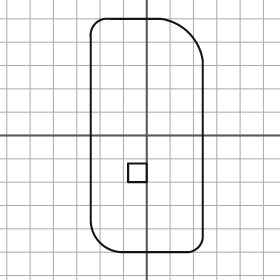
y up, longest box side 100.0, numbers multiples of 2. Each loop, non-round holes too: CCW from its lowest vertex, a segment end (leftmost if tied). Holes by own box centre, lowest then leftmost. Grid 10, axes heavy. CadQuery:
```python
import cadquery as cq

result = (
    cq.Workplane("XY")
    .moveTo(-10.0, -50.0)
    .lineTo(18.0, -50.0)
    .threePointArc((22.0, -48.0), (24.0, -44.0))
    .lineTo(24.0, 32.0)
    .threePointArc((18.0, 44.0), (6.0, 50.0))
    .lineTo(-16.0, 50.0)
    .threePointArc((-22.0, 48.0), (-24.0, 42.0))
    .lineTo(-24.0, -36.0)
    .threePointArc((-20.0, -46.0), (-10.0, -50.0))
    .close()
    .moveTo(-8.0, -20.0)
    .lineTo(0.0, -20.0)
    .lineTo(0.0, -12.0)
    .lineTo(-8.0, -12.0)
    .close()
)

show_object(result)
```